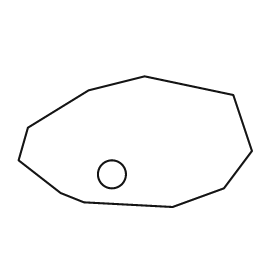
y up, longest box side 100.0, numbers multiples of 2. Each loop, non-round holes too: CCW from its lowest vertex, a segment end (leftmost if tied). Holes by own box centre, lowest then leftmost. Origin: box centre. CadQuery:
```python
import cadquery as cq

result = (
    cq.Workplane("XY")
    .moveTo(16.0, -28.0)
    .lineTo(38.0, -20.0)
    .lineTo(50.0, -4.0)
    .lineTo(42.0, 20.0)
    .lineTo(4.0, 28.0)
    .lineTo(-20.0, 22.0)
    .lineTo(-46.0, 6.0)
    .lineTo(-50.0, -8.0)
    .lineTo(-32.0, -22.0)
    .lineTo(-22.0, -26.0)
    .close()
    .moveTo(-10.0, -14.0)
    .circle(6.0)
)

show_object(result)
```